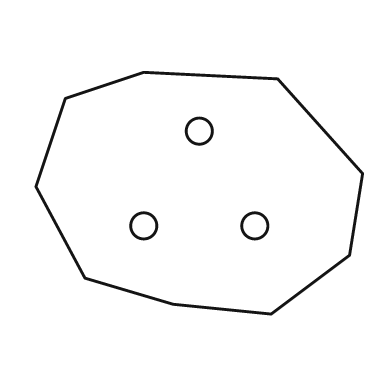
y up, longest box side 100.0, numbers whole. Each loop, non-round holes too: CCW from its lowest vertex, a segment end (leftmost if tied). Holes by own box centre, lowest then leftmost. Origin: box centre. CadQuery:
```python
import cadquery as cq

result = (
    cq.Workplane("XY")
    .moveTo(22.0, -37.0)
    .lineTo(46.0, -19.0)
    .lineTo(50.0, 6.0)
    .lineTo(24.0, 35.0)
    .lineTo(-17.0, 37.0)
    .lineTo(-41.0, 29.0)
    .lineTo(-50.0, 2.0)
    .lineTo(-35.0, -26.0)
    .lineTo(-8.0, -34.0)
    .close()
    .moveTo(-17.0, -10.0)
    .circle(4.0)
    .moveTo(17.0, -10.0)
    .circle(4.0)
    .moveTo(0.0, 19.0)
    .circle(4.0)
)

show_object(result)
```